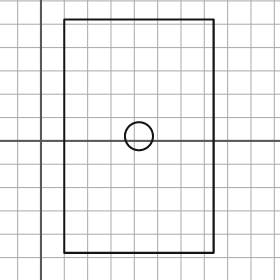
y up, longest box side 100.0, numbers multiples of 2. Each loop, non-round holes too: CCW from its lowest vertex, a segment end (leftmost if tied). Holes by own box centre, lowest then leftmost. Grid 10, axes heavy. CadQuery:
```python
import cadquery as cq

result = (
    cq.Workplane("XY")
    .moveTo(10.0, -48.0)
    .lineTo(74.0, -48.0)
    .lineTo(74.0, 52.0)
    .lineTo(10.0, 52.0)
    .close()
    .moveTo(42.0, 2.0)
    .circle(6.0)
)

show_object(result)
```